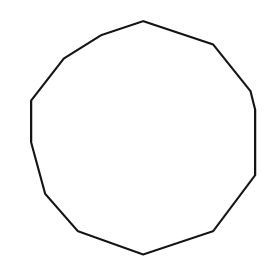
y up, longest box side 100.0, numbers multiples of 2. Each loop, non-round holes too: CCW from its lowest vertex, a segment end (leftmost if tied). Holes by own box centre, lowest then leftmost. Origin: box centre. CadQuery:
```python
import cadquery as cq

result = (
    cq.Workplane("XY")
    .moveTo(0.0, -50.0)
    .lineTo(30.0, -40.0)
    .lineTo(48.0, -16.0)
    .lineTo(48.0, 12.0)
    .lineTo(46.0, 20.0)
    .lineTo(30.0, 40.0)
    .lineTo(0.0, 50.0)
    .lineTo(-18.0, 44.0)
    .lineTo(-34.0, 34.0)
    .lineTo(-48.0, 16.0)
    .lineTo(-48.0, -2.0)
    .lineTo(-42.0, -24.0)
    .lineTo(-28.0, -40.0)
    .close()
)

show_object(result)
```